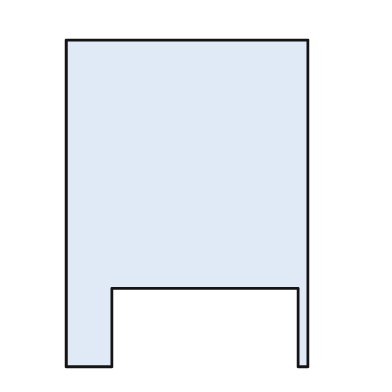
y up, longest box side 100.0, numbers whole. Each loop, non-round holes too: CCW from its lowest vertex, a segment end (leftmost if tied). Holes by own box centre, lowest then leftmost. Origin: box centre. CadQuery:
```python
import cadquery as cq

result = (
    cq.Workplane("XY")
    .moveTo(-37.0, -50.0)
    .lineTo(-23.0, -50.0)
    .lineTo(-23.0, -26.0)
    .lineTo(34.0, -26.0)
    .lineTo(34.0, -50.0)
    .lineTo(37.0, -50.0)
    .lineTo(37.0, 50.0)
    .lineTo(-37.0, 50.0)
    .close()
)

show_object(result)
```